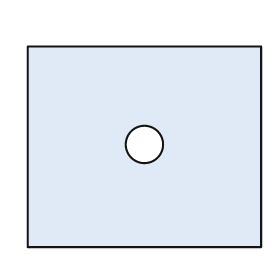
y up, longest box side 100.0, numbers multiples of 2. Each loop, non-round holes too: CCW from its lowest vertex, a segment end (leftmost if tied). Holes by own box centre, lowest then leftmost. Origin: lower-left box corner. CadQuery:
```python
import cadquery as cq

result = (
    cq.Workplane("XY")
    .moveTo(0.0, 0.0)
    .lineTo(100.0, 0.0)
    .lineTo(100.0, 86.0)
    .lineTo(0.0, 86.0)
    .close()
    .moveTo(50.0, 44.0)
    .circle(8.0)
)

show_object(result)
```